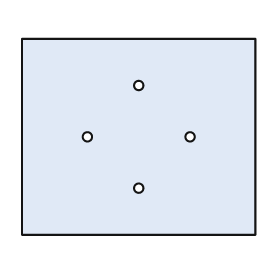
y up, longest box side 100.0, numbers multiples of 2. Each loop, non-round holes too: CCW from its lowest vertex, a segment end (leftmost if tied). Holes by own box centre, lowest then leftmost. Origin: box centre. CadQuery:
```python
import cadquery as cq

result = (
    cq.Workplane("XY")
    .moveTo(-50.0, -42.0)
    .lineTo(50.0, -42.0)
    .lineTo(50.0, 42.0)
    .lineTo(-50.0, 42.0)
    .close()
    .moveTo(0.0, -22.0)
    .circle(2.0)
    .moveTo(-22.0, 0.0)
    .circle(2.0)
    .moveTo(22.0, 0.0)
    .circle(2.0)
    .moveTo(0.0, 22.0)
    .circle(2.0)
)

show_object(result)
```